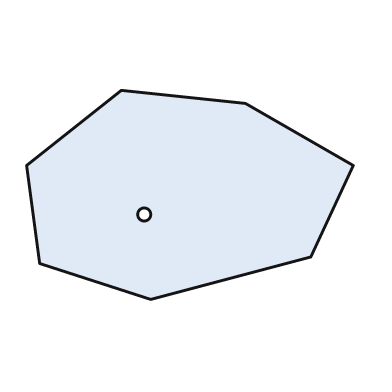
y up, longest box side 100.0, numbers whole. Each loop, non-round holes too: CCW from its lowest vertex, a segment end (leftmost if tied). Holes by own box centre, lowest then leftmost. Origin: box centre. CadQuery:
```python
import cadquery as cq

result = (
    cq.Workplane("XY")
    .moveTo(-12.0, -32.0)
    .lineTo(37.0, -19.0)
    .lineTo(50.0, 9.0)
    .lineTo(17.0, 28.0)
    .lineTo(-21.0, 32.0)
    .lineTo(-50.0, 9.0)
    .lineTo(-46.0, -21.0)
    .close()
    .moveTo(-14.0, -6.0)
    .circle(2.0)
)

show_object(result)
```